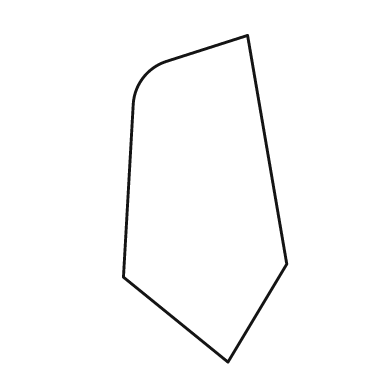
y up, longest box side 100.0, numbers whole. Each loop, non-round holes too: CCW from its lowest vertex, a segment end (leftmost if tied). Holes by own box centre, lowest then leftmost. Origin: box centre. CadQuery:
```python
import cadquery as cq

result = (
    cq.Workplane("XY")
    .moveTo(7.0, -50.0)
    .lineTo(25.0, -20.0)
    .lineTo(13.0, 50.0)
    .lineTo(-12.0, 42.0)
    .threePointArc((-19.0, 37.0), (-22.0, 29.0))
    .lineTo(-25.0, -24.0)
    .close()
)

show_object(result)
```